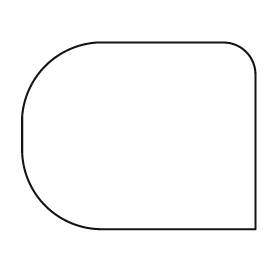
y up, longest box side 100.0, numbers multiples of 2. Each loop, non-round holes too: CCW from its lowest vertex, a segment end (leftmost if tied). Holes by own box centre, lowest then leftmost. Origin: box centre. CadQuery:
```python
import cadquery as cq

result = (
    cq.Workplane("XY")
    .moveTo(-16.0, -40.0)
    .lineTo(50.0, -40.0)
    .lineTo(50.0, 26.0)
    .threePointArc((46.0, 36.0), (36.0, 40.0))
    .lineTo(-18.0, 40.0)
    .threePointArc((-40.0, 30.0), (-50.0, 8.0))
    .lineTo(-50.0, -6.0)
    .threePointArc((-40.0, -30.0), (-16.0, -40.0))
    .close()
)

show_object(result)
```